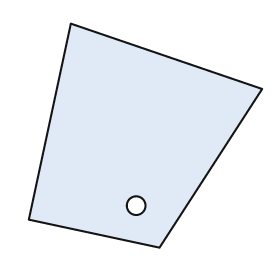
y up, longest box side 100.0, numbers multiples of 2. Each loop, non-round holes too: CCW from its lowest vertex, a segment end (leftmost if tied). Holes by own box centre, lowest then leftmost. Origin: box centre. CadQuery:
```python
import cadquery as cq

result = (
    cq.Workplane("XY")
    .moveTo(6.0, -48.0)
    .lineTo(50.0, 20.0)
    .lineTo(-32.0, 48.0)
    .lineTo(-50.0, -36.0)
    .close()
    .moveTo(-4.0, -30.0)
    .circle(4.0)
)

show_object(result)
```